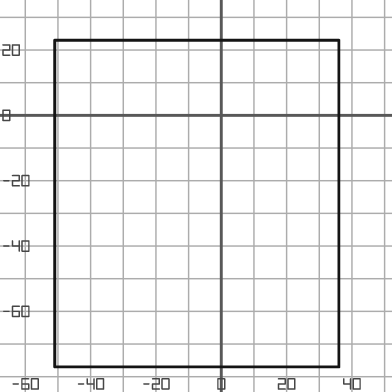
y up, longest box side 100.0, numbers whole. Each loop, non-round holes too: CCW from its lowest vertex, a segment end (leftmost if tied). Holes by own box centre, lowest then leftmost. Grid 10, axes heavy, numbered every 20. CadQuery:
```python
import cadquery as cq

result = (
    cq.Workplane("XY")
    .moveTo(-51.0, -77.0)
    .lineTo(36.0, -77.0)
    .lineTo(36.0, 23.0)
    .lineTo(-51.0, 23.0)
    .close()
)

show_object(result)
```